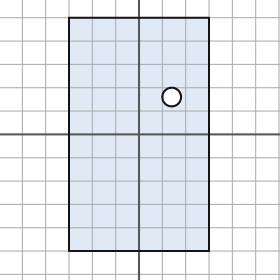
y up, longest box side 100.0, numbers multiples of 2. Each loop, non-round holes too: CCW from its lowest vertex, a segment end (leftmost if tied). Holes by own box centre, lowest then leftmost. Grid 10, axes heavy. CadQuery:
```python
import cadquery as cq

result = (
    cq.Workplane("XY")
    .moveTo(-30.0, -50.0)
    .lineTo(30.0, -50.0)
    .lineTo(30.0, 50.0)
    .lineTo(-30.0, 50.0)
    .close()
    .moveTo(14.0, 16.0)
    .circle(4.0)
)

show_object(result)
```